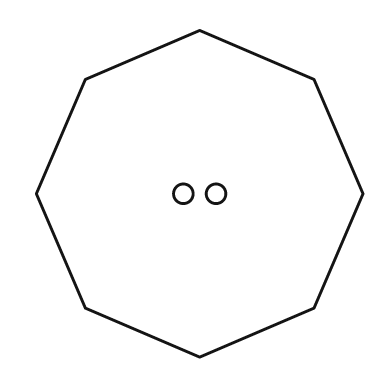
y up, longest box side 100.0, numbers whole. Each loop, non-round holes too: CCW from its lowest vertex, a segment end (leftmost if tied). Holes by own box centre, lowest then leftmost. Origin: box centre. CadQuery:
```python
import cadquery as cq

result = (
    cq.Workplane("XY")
    .moveTo(0.0, -50.0)
    .lineTo(35.0, -35.0)
    .lineTo(50.0, 0.0)
    .lineTo(35.0, 35.0)
    .lineTo(0.0, 50.0)
    .lineTo(-35.0, 35.0)
    .lineTo(-50.0, 0.0)
    .lineTo(-35.0, -35.0)
    .close()
    .moveTo(-5.0, 0.0)
    .circle(3.0)
    .moveTo(5.0, 0.0)
    .circle(3.0)
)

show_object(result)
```